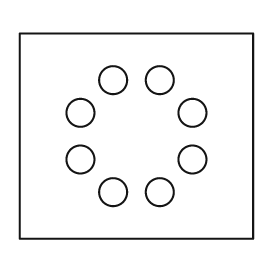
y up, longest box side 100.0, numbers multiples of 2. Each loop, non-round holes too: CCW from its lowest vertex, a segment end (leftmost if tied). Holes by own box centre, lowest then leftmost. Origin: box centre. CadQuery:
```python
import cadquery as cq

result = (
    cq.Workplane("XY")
    .moveTo(-50.0, -44.0)
    .lineTo(50.0, -44.0)
    .lineTo(50.0, 44.0)
    .lineTo(-50.0, 44.0)
    .close()
    .moveTo(-10.0, -24.0)
    .circle(6.0)
    .moveTo(10.0, -24.0)
    .circle(6.0)
    .moveTo(-24.0, -10.0)
    .circle(6.0)
    .moveTo(24.0, -10.0)
    .circle(6.0)
    .moveTo(-24.0, 10.0)
    .circle(6.0)
    .moveTo(24.0, 10.0)
    .circle(6.0)
    .moveTo(-10.0, 24.0)
    .circle(6.0)
    .moveTo(10.0, 24.0)
    .circle(6.0)
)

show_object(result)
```